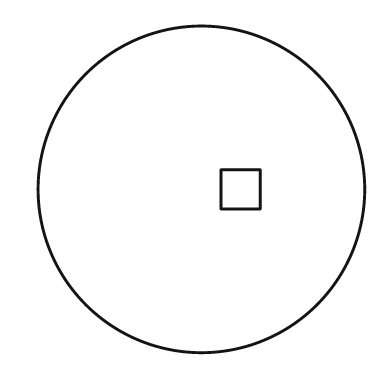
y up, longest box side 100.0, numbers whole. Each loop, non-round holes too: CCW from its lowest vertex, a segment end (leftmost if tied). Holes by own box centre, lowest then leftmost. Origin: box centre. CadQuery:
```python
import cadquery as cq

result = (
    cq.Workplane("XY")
    .moveTo(0.0, 0.0)
    .circle(50.0)
    .moveTo(6.0, -6.0)
    .lineTo(18.0, -6.0)
    .lineTo(18.0, 6.0)
    .lineTo(6.0, 6.0)
    .close()
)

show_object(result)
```